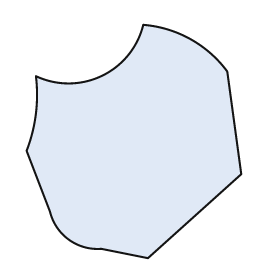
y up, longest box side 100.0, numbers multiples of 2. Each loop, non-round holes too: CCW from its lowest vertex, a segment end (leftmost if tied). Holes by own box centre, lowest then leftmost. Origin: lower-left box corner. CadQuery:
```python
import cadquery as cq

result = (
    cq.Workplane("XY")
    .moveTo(52.0, 0.0)
    .lineTo(92.0, 36.0)
    .lineTo(86.0, 80.0)
    .threePointArc((70.0, 94.0), (50.0, 100.0))
    .threePointArc((32.0, 78.0), (4.0, 78.0))
    .threePointArc((4.0, 62.0), (0.0, 46.0))
    .lineTo(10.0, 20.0)
    .threePointArc((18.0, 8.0), (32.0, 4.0))
    .close()
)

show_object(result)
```